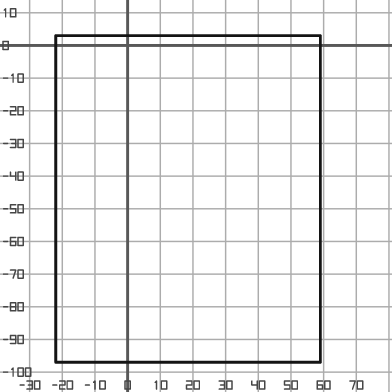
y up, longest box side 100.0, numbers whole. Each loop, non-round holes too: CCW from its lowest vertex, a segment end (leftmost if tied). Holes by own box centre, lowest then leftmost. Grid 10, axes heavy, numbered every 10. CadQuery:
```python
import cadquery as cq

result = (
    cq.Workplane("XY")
    .moveTo(-22.0, -97.0)
    .lineTo(59.0, -97.0)
    .lineTo(59.0, 3.0)
    .lineTo(-22.0, 3.0)
    .close()
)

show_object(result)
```